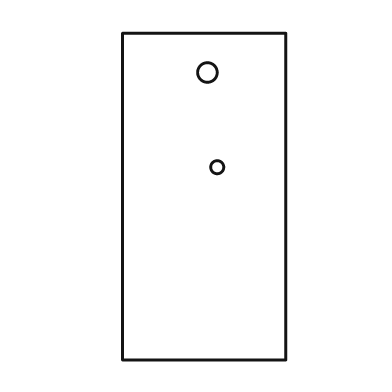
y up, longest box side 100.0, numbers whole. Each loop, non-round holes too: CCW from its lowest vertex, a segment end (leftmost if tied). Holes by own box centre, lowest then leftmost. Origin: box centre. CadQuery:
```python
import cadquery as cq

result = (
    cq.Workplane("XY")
    .moveTo(-25.0, -50.0)
    .lineTo(25.0, -50.0)
    .lineTo(25.0, 50.0)
    .lineTo(-25.0, 50.0)
    .close()
    .moveTo(4.0, 9.0)
    .circle(2.0)
    .moveTo(1.0, 38.0)
    .circle(3.0)
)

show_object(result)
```